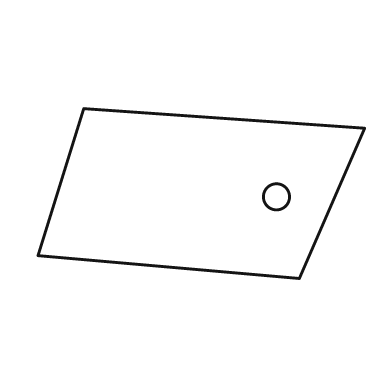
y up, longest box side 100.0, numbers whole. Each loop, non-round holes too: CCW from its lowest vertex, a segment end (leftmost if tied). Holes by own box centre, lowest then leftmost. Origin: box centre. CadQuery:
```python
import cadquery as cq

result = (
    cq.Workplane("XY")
    .moveTo(30.0, -26.0)
    .lineTo(50.0, 20.0)
    .lineTo(-36.0, 26.0)
    .lineTo(-50.0, -19.0)
    .close()
    .moveTo(23.0, -1.0)
    .circle(4.0)
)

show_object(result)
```